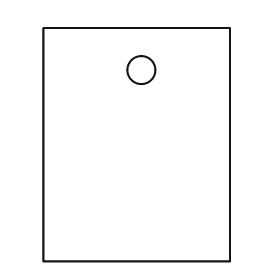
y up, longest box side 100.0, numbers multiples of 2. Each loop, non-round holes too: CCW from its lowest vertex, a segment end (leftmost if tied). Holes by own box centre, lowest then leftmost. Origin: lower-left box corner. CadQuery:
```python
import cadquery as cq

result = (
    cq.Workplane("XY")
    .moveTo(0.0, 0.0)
    .lineTo(80.0, 0.0)
    .lineTo(80.0, 100.0)
    .lineTo(0.0, 100.0)
    .close()
    .moveTo(42.0, 82.0)
    .circle(6.0)
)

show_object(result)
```